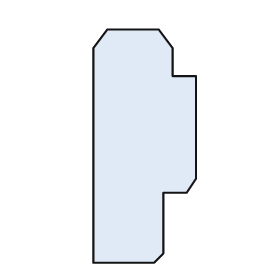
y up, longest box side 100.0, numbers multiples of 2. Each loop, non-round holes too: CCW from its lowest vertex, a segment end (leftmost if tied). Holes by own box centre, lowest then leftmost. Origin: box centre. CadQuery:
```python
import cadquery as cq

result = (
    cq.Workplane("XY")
    .moveTo(-22.0, -50.0)
    .lineTo(4.0, -50.0)
    .lineTo(8.0, -46.0)
    .lineTo(8.0, -20.0)
    .lineTo(18.0, -20.0)
    .lineTo(22.0, -14.0)
    .lineTo(22.0, 30.0)
    .lineTo(12.0, 30.0)
    .lineTo(12.0, 42.0)
    .lineTo(6.0, 50.0)
    .lineTo(-16.0, 50.0)
    .lineTo(-22.0, 42.0)
    .close()
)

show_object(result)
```